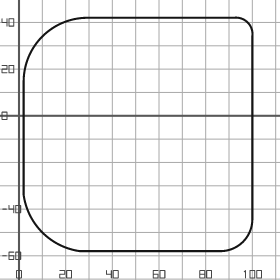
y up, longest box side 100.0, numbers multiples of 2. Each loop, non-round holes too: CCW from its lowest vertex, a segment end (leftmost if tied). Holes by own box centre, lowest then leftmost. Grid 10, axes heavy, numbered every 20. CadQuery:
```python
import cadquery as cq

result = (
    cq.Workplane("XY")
    .moveTo(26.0, -58.0)
    .lineTo(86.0, -58.0)
    .threePointArc((96.0, -54.0), (100.0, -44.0))
    .lineTo(100.0, 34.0)
    .threePointArc((98.0, 40.0), (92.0, 42.0))
    .lineTo(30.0, 42.0)
    .threePointArc((10.0, 34.0), (2.0, 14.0))
    .lineTo(2.0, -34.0)
    .threePointArc((10.0, -50.0), (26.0, -58.0))
    .close()
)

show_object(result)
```